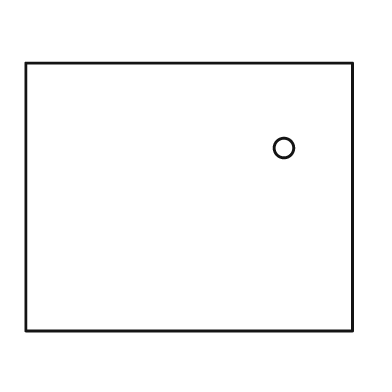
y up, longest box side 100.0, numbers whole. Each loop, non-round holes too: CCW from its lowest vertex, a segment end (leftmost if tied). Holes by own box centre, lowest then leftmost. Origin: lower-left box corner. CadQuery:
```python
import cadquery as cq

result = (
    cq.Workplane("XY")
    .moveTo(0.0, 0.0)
    .lineTo(100.0, 0.0)
    .lineTo(100.0, 82.0)
    .lineTo(0.0, 82.0)
    .close()
    .moveTo(79.0, 56.0)
    .circle(3.0)
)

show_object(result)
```